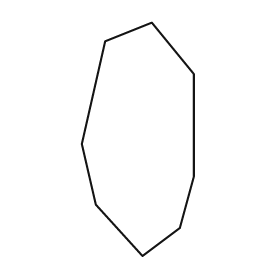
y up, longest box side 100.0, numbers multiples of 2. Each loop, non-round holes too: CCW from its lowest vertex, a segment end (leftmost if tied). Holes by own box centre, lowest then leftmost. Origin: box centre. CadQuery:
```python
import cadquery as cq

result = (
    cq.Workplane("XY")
    .moveTo(2.0, -50.0)
    .lineTo(18.0, -38.0)
    .lineTo(24.0, -16.0)
    .lineTo(24.0, 28.0)
    .lineTo(6.0, 50.0)
    .lineTo(-14.0, 42.0)
    .lineTo(-24.0, -2.0)
    .lineTo(-18.0, -28.0)
    .close()
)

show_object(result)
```